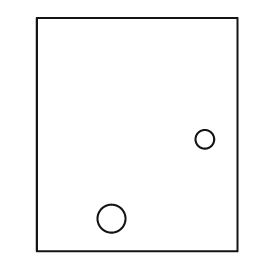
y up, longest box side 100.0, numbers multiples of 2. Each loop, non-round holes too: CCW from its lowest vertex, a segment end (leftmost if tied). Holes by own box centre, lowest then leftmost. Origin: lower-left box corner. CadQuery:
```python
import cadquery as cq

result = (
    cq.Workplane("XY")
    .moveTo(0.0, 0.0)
    .lineTo(86.0, 0.0)
    .lineTo(86.0, 100.0)
    .lineTo(0.0, 100.0)
    .close()
    .moveTo(32.0, 14.0)
    .circle(6.0)
    .moveTo(72.0, 48.0)
    .circle(4.0)
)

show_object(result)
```